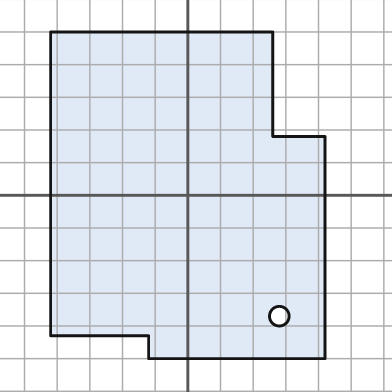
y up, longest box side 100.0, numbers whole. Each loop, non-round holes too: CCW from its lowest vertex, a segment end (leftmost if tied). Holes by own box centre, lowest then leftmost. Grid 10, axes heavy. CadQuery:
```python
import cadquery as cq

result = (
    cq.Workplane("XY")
    .moveTo(-12.0, -50.0)
    .lineTo(42.0, -50.0)
    .lineTo(42.0, 18.0)
    .lineTo(26.0, 18.0)
    .lineTo(26.0, 50.0)
    .lineTo(-42.0, 50.0)
    .lineTo(-42.0, -43.0)
    .lineTo(-12.0, -43.0)
    .close()
    .moveTo(28.0, -37.0)
    .circle(3.0)
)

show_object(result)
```